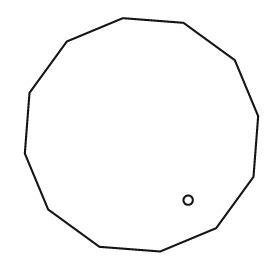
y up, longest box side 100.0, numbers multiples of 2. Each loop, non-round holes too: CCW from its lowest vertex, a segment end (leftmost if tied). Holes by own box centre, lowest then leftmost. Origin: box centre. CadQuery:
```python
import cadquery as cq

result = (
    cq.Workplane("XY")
    .moveTo(8.0, -50.0)
    .lineTo(32.0, -40.0)
    .lineTo(48.0, -18.0)
    .lineTo(50.0, 8.0)
    .lineTo(40.0, 32.0)
    .lineTo(18.0, 48.0)
    .lineTo(-8.0, 50.0)
    .lineTo(-32.0, 40.0)
    .lineTo(-48.0, 18.0)
    .lineTo(-50.0, -8.0)
    .lineTo(-40.0, -32.0)
    .lineTo(-18.0, -48.0)
    .close()
    .moveTo(20.0, -28.0)
    .circle(2.0)
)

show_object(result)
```